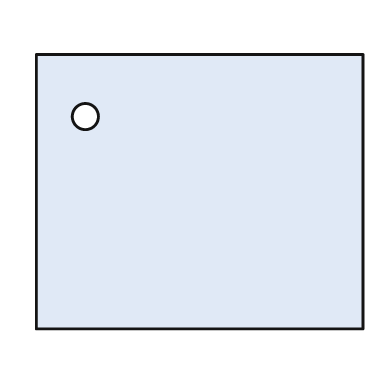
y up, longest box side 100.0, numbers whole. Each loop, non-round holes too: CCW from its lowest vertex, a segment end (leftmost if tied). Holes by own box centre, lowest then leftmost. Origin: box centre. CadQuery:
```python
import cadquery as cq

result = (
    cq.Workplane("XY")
    .moveTo(-50.0, -42.0)
    .lineTo(50.0, -42.0)
    .lineTo(50.0, 42.0)
    .lineTo(-50.0, 42.0)
    .close()
    .moveTo(-35.0, 23.0)
    .circle(4.0)
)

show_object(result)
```